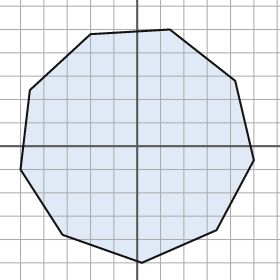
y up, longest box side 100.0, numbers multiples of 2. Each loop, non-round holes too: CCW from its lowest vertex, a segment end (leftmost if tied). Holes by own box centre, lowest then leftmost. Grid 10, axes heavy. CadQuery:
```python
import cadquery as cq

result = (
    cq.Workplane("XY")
    .moveTo(2.0, -50.0)
    .lineTo(34.0, -36.0)
    .lineTo(50.0, -6.0)
    .lineTo(42.0, 28.0)
    .lineTo(14.0, 50.0)
    .lineTo(-20.0, 48.0)
    .lineTo(-46.0, 24.0)
    .lineTo(-50.0, -10.0)
    .lineTo(-32.0, -38.0)
    .close()
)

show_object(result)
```